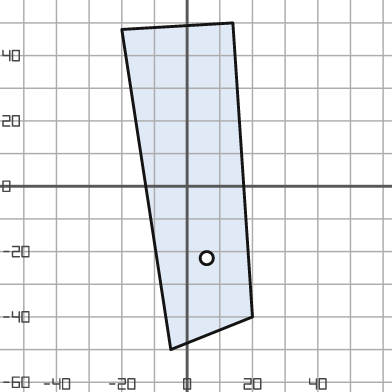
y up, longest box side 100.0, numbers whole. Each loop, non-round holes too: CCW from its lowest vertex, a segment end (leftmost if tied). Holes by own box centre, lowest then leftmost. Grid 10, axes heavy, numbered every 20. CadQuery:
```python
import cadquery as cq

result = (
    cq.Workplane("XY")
    .moveTo(-5.0, -50.0)
    .lineTo(20.0, -40.0)
    .lineTo(14.0, 50.0)
    .lineTo(-20.0, 48.0)
    .close()
    .moveTo(6.0, -22.0)
    .circle(2.0)
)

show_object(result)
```